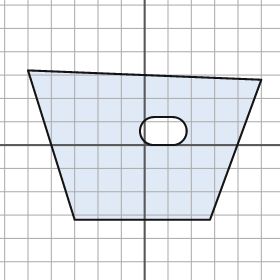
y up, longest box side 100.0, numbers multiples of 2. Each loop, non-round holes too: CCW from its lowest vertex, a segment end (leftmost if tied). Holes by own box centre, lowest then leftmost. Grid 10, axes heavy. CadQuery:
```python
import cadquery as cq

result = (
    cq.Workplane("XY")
    .moveTo(-30.0, -32.0)
    .lineTo(28.0, -32.0)
    .lineTo(50.0, 28.0)
    .lineTo(-50.0, 32.0)
    .close()
    .moveTo(4.0, 0.0)
    .lineTo(12.0, 0.0)
    .threePointArc((18.0, 6.0), (12.0, 12.0))
    .lineTo(4.0, 12.0)
    .threePointArc((-2.0, 6.0), (4.0, 0.0))
    .close()
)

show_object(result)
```